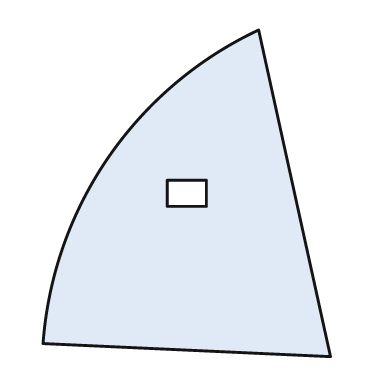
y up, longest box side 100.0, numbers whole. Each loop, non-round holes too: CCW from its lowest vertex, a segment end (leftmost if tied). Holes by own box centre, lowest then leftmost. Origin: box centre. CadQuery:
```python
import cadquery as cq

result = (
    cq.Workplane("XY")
    .moveTo(44.0, -50.0)
    .lineTo(22.0, 50.0)
    .threePointArc((-24.0, 11.0), (-44.0, -46.0))
    .close()
    .moveTo(-6.0, -4.0)
    .lineTo(6.0, -4.0)
    .lineTo(6.0, 4.0)
    .lineTo(-6.0, 4.0)
    .close()
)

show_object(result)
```